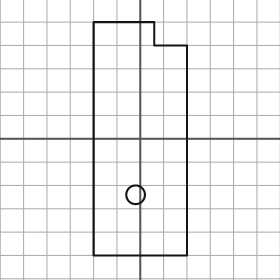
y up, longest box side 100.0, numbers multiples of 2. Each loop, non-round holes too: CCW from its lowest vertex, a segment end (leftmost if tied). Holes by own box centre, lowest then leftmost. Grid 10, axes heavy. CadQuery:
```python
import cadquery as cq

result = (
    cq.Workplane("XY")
    .moveTo(-20.0, -50.0)
    .lineTo(20.0, -50.0)
    .lineTo(20.0, 40.0)
    .lineTo(6.0, 40.0)
    .lineTo(6.0, 50.0)
    .lineTo(-20.0, 50.0)
    .close()
    .moveTo(-2.0, -24.0)
    .circle(4.0)
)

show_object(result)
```